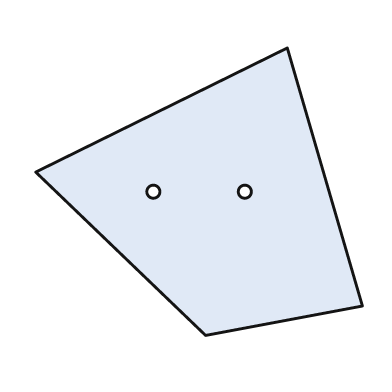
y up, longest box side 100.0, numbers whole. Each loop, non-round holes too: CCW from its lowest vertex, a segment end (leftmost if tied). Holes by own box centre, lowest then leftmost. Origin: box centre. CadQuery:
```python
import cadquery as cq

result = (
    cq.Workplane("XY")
    .moveTo(2.0, -44.0)
    .lineTo(50.0, -35.0)
    .lineTo(27.0, 44.0)
    .lineTo(-50.0, 6.0)
    .close()
    .moveTo(-14.0, 0.0)
    .circle(2.0)
    .moveTo(14.0, 0.0)
    .circle(2.0)
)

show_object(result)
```